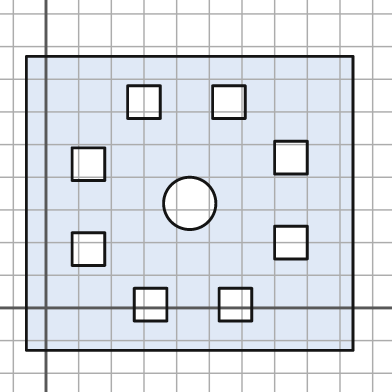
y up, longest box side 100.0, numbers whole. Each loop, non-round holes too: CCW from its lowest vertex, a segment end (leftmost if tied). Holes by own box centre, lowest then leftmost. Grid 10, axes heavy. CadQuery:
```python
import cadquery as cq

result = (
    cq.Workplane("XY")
    .moveTo(-6.0, -13.0)
    .lineTo(94.0, -13.0)
    .lineTo(94.0, 77.0)
    .lineTo(-6.0, 77.0)
    .close()
    .moveTo(27.0, -4.0)
    .lineTo(37.0, -4.0)
    .lineTo(37.0, 6.0)
    .lineTo(27.0, 6.0)
    .close()
    .moveTo(53.0, -4.0)
    .lineTo(63.0, -4.0)
    .lineTo(63.0, 6.0)
    .lineTo(53.0, 6.0)
    .close()
    .moveTo(8.0, 13.0)
    .lineTo(18.0, 13.0)
    .lineTo(18.0, 23.0)
    .lineTo(8.0, 23.0)
    .close()
    .moveTo(70.0, 15.0)
    .lineTo(80.0, 15.0)
    .lineTo(80.0, 25.0)
    .lineTo(70.0, 25.0)
    .close()
    .moveTo(44.0, 32.0)
    .circle(8.0)
    .moveTo(8.0, 39.0)
    .lineTo(18.0, 39.0)
    .lineTo(18.0, 49.0)
    .lineTo(8.0, 49.0)
    .close()
    .moveTo(70.0, 41.0)
    .lineTo(80.0, 41.0)
    .lineTo(80.0, 51.0)
    .lineTo(70.0, 51.0)
    .close()
    .moveTo(25.0, 58.0)
    .lineTo(35.0, 58.0)
    .lineTo(35.0, 68.0)
    .lineTo(25.0, 68.0)
    .close()
    .moveTo(51.0, 58.0)
    .lineTo(61.0, 58.0)
    .lineTo(61.0, 68.0)
    .lineTo(51.0, 68.0)
    .close()
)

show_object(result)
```